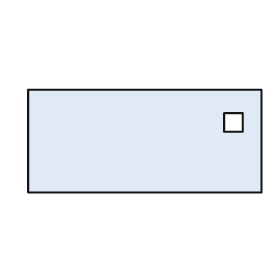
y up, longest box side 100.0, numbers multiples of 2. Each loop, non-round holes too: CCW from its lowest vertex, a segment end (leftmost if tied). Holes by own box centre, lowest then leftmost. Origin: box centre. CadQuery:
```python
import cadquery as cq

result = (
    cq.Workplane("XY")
    .moveTo(-50.0, -22.0)
    .lineTo(50.0, -22.0)
    .lineTo(50.0, 22.0)
    .lineTo(-50.0, 22.0)
    .close()
    .moveTo(34.0, 4.0)
    .lineTo(42.0, 4.0)
    .lineTo(42.0, 12.0)
    .lineTo(34.0, 12.0)
    .close()
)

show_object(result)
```